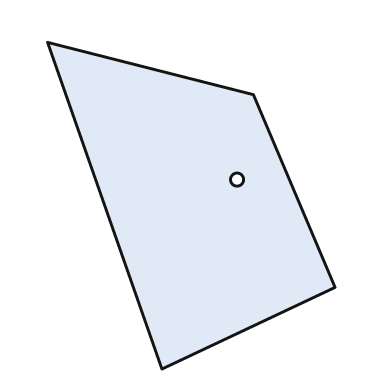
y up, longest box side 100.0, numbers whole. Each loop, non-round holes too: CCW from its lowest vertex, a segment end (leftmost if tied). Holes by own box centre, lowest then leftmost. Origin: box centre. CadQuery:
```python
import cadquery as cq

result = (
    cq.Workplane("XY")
    .moveTo(-9.0, -50.0)
    .lineTo(44.0, -25.0)
    .lineTo(19.0, 34.0)
    .lineTo(-44.0, 50.0)
    .close()
    .moveTo(14.0, 8.0)
    .circle(2.0)
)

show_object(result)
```